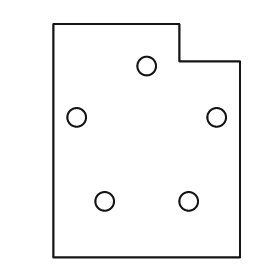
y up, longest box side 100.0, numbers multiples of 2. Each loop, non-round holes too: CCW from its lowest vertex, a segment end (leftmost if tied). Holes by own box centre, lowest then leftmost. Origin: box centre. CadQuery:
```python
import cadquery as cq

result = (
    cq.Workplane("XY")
    .moveTo(-40.0, -50.0)
    .lineTo(40.0, -50.0)
    .lineTo(40.0, 34.0)
    .lineTo(14.0, 34.0)
    .lineTo(14.0, 50.0)
    .lineTo(-40.0, 50.0)
    .close()
    .moveTo(-18.0, -26.0)
    .circle(4.0)
    .moveTo(18.0, -26.0)
    .circle(4.0)
    .moveTo(-30.0, 10.0)
    .circle(4.0)
    .moveTo(30.0, 10.0)
    .circle(4.0)
    .moveTo(0.0, 32.0)
    .circle(4.0)
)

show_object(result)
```